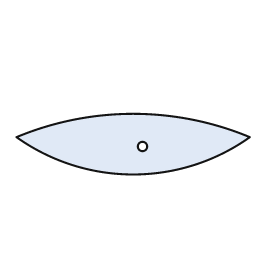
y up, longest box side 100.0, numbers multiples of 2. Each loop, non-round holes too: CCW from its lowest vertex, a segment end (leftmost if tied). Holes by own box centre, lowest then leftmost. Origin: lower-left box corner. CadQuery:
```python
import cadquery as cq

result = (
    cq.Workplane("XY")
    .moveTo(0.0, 16.0)
    .threePointArc((50.0, 0.0), (100.0, 16.0))
    .threePointArc((50.0, 26.0), (0.0, 16.0))
    .close()
    .moveTo(54.0, 12.0)
    .circle(2.0)
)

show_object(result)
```